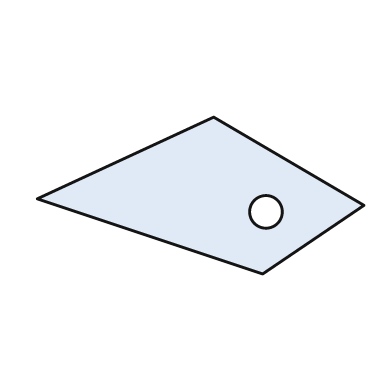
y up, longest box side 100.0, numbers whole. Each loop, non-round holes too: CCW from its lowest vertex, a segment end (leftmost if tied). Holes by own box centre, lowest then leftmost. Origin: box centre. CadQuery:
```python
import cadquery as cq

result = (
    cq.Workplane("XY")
    .moveTo(19.0, -24.0)
    .lineTo(50.0, -3.0)
    .lineTo(4.0, 24.0)
    .lineTo(-50.0, -1.0)
    .close()
    .moveTo(20.0, -5.0)
    .circle(5.0)
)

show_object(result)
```